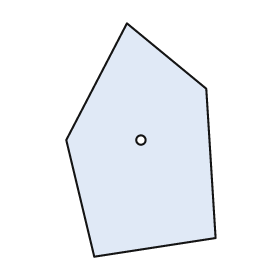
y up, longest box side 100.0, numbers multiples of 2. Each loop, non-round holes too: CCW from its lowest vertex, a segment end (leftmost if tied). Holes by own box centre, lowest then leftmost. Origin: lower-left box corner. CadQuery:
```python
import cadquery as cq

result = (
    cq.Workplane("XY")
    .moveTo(12.0, 0.0)
    .lineTo(64.0, 8.0)
    .lineTo(60.0, 72.0)
    .lineTo(26.0, 100.0)
    .lineTo(0.0, 50.0)
    .close()
    .moveTo(32.0, 50.0)
    .circle(2.0)
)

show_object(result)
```